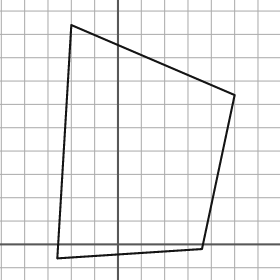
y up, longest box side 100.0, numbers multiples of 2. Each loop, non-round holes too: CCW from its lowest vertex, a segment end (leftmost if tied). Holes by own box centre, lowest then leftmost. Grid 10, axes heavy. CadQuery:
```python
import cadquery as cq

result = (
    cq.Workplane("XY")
    .moveTo(-26.0, -6.0)
    .lineTo(36.0, -2.0)
    .lineTo(50.0, 64.0)
    .lineTo(-20.0, 94.0)
    .close()
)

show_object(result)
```